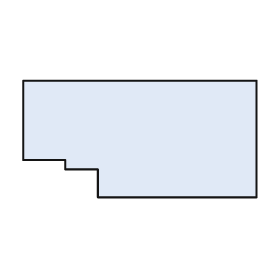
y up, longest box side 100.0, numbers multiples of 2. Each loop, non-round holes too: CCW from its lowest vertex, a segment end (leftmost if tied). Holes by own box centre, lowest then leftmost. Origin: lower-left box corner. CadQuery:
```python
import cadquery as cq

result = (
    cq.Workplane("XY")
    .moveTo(32.0, 0.0)
    .lineTo(100.0, 0.0)
    .lineTo(100.0, 50.0)
    .lineTo(0.0, 50.0)
    .lineTo(0.0, 16.0)
    .lineTo(18.0, 16.0)
    .lineTo(18.0, 12.0)
    .lineTo(32.0, 12.0)
    .close()
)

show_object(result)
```